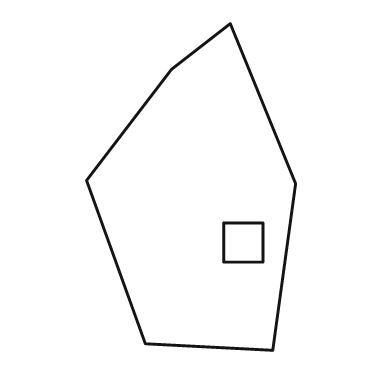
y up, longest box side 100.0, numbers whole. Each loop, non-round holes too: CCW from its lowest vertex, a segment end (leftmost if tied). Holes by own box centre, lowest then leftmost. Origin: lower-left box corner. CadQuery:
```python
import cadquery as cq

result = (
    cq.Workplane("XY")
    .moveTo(57.0, 0.0)
    .lineTo(64.0, 51.0)
    .lineTo(44.0, 100.0)
    .lineTo(26.0, 86.0)
    .lineTo(0.0, 52.0)
    .lineTo(18.0, 2.0)
    .close()
    .moveTo(42.0, 27.0)
    .lineTo(54.0, 27.0)
    .lineTo(54.0, 39.0)
    .lineTo(42.0, 39.0)
    .close()
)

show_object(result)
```